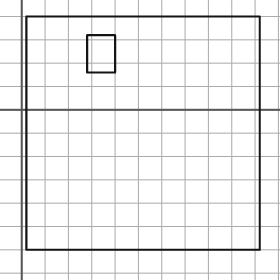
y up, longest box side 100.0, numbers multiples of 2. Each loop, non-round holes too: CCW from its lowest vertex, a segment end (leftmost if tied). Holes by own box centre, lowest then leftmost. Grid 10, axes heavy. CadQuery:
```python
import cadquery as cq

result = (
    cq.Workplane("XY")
    .moveTo(2.0, -60.0)
    .lineTo(102.0, -60.0)
    .lineTo(102.0, 40.0)
    .lineTo(2.0, 40.0)
    .close()
    .moveTo(28.0, 16.0)
    .lineTo(40.0, 16.0)
    .lineTo(40.0, 32.0)
    .lineTo(28.0, 32.0)
    .close()
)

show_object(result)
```